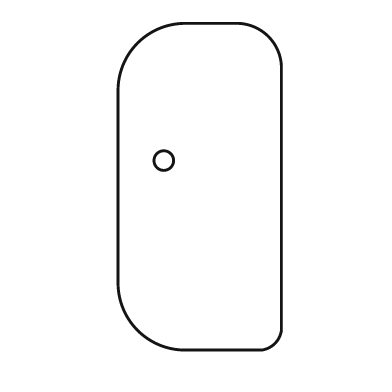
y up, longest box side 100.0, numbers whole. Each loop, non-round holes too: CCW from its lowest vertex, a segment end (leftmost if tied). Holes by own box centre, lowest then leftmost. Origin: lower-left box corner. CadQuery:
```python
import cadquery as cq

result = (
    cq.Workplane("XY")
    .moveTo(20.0, 0.0)
    .lineTo(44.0, 0.0)
    .threePointArc((48.0, 2.0), (50.0, 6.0))
    .lineTo(50.0, 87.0)
    .threePointArc((46.0, 96.0), (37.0, 100.0))
    .lineTo(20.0, 100.0)
    .threePointArc((6.0, 94.0), (0.0, 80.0))
    .lineTo(0.0, 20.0)
    .threePointArc((6.0, 6.0), (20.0, 0.0))
    .close()
    .moveTo(14.0, 58.0)
    .circle(3.0)
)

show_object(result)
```